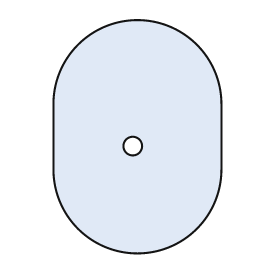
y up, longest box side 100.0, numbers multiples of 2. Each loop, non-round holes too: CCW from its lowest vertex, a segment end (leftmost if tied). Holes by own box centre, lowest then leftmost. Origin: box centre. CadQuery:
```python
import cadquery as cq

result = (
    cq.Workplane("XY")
    .moveTo(-36.0, -14.0)
    .threePointArc((0.0, -50.0), (36.0, -14.0))
    .lineTo(36.0, 14.0)
    .threePointArc((0.0, 50.0), (-36.0, 14.0))
    .close()
    .moveTo(-2.0, -4.0)
    .circle(4.0)
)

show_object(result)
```